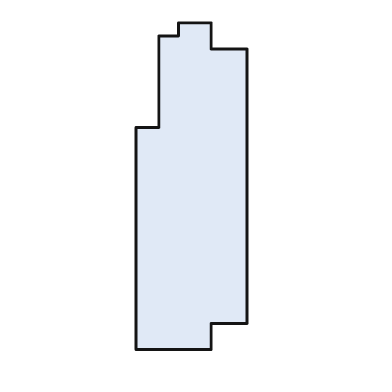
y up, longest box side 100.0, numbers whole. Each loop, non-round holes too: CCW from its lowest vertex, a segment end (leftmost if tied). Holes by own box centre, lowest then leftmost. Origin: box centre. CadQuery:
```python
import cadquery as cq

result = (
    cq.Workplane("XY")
    .moveTo(-17.0, -50.0)
    .lineTo(6.0, -50.0)
    .lineTo(6.0, -42.0)
    .lineTo(17.0, -42.0)
    .lineTo(17.0, 42.0)
    .lineTo(6.0, 42.0)
    .lineTo(6.0, 50.0)
    .lineTo(-4.0, 50.0)
    .lineTo(-4.0, 46.0)
    .lineTo(-10.0, 46.0)
    .lineTo(-10.0, 18.0)
    .lineTo(-17.0, 18.0)
    .close()
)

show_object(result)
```